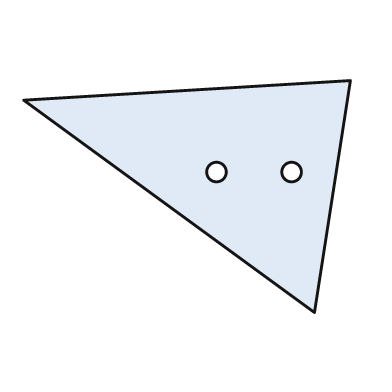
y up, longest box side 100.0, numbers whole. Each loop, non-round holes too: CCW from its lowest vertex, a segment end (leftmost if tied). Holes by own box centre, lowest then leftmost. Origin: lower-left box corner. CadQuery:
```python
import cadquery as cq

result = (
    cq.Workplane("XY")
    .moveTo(89.0, 0.0)
    .lineTo(100.0, 71.0)
    .lineTo(0.0, 65.0)
    .close()
    .moveTo(59.0, 43.0)
    .circle(3.0)
    .moveTo(82.0, 43.0)
    .circle(3.0)
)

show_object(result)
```